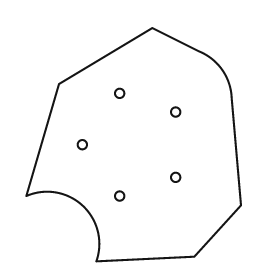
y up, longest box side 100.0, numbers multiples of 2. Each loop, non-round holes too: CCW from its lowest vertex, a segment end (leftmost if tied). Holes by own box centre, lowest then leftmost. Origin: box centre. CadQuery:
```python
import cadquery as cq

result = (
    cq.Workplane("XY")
    .moveTo(-16.0, -50.0)
    .lineTo(26.0, -48.0)
    .lineTo(46.0, -26.0)
    .lineTo(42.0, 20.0)
    .threePointArc((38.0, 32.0), (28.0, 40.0))
    .lineTo(8.0, 50.0)
    .lineTo(-32.0, 26.0)
    .lineTo(-46.0, -22.0)
    .threePointArc((-22.0, -26.0), (-16.0, -50.0))
    .close()
    .moveTo(-6.0, -22.0)
    .circle(2.0)
    .moveTo(18.0, -14.0)
    .circle(2.0)
    .moveTo(-22.0, 0.0)
    .circle(2.0)
    .moveTo(18.0, 14.0)
    .circle(2.0)
    .moveTo(-6.0, 22.0)
    .circle(2.0)
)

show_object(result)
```